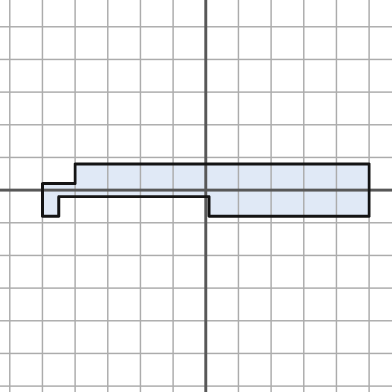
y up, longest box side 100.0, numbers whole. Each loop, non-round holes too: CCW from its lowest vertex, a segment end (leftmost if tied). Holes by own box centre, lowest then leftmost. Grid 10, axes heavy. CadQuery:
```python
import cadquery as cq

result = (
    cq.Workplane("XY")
    .moveTo(-50.0, -8.0)
    .lineTo(-45.0, -8.0)
    .lineTo(-45.0, -2.0)
    .lineTo(1.0, -2.0)
    .lineTo(1.0, -8.0)
    .lineTo(50.0, -8.0)
    .lineTo(50.0, 8.0)
    .lineTo(-40.0, 8.0)
    .lineTo(-40.0, 2.0)
    .lineTo(-50.0, 2.0)
    .close()
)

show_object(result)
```